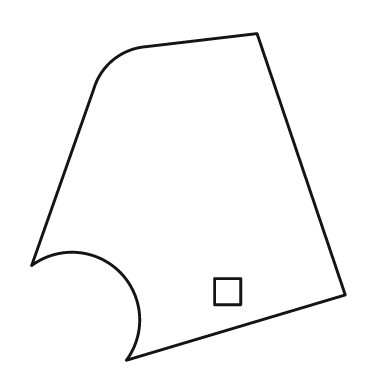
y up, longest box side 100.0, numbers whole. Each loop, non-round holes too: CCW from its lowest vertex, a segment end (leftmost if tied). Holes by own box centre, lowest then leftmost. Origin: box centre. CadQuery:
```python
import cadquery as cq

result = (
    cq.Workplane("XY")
    .moveTo(-19.0, -50.0)
    .lineTo(48.0, -30.0)
    .lineTo(21.0, 50.0)
    .lineTo(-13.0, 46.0)
    .threePointArc((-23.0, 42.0), (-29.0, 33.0))
    .lineTo(-48.0, -21.0)
    .threePointArc((-21.0, -23.0), (-19.0, -50.0))
    .close()
    .moveTo(8.0, -33.0)
    .lineTo(16.0, -33.0)
    .lineTo(16.0, -25.0)
    .lineTo(8.0, -25.0)
    .close()
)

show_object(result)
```